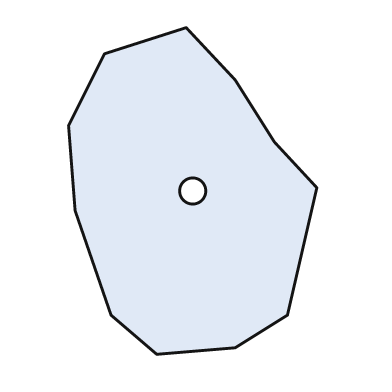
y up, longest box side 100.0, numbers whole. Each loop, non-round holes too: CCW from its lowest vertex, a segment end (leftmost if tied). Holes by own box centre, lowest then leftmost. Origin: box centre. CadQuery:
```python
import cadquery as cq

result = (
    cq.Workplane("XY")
    .moveTo(-11.0, -50.0)
    .lineTo(13.0, -48.0)
    .lineTo(29.0, -38.0)
    .lineTo(38.0, 1.0)
    .lineTo(25.0, 15.0)
    .lineTo(13.0, 34.0)
    .lineTo(-2.0, 50.0)
    .lineTo(-27.0, 42.0)
    .lineTo(-38.0, 20.0)
    .lineTo(-36.0, -6.0)
    .lineTo(-25.0, -38.0)
    .close()
    .moveTo(0.0, 0.0)
    .circle(4.0)
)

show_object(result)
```